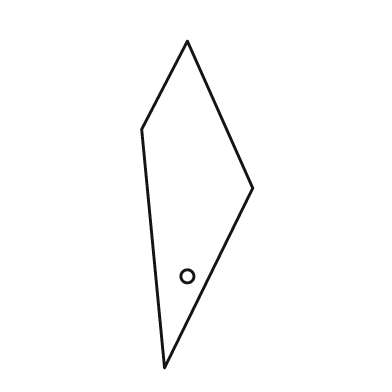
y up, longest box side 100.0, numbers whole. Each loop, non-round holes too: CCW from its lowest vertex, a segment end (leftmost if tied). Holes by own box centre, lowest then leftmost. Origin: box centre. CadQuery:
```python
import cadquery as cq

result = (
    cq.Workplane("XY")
    .moveTo(-10.0, -50.0)
    .lineTo(17.0, 5.0)
    .lineTo(-3.0, 50.0)
    .lineTo(-17.0, 23.0)
    .close()
    .moveTo(-3.0, -22.0)
    .circle(2.0)
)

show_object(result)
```